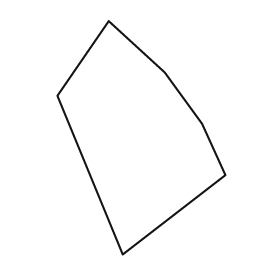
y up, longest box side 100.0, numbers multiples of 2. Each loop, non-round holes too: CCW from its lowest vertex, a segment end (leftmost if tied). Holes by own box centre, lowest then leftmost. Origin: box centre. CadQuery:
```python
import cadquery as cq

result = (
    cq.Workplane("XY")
    .moveTo(-8.0, -50.0)
    .lineTo(36.0, -16.0)
    .lineTo(26.0, 6.0)
    .lineTo(10.0, 28.0)
    .lineTo(-14.0, 50.0)
    .lineTo(-36.0, 18.0)
    .close()
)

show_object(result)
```